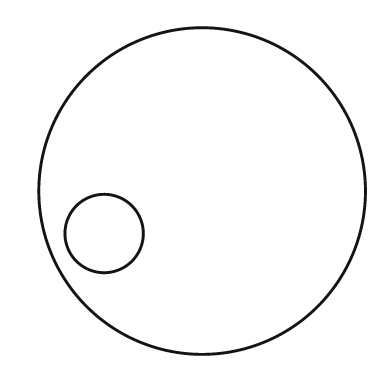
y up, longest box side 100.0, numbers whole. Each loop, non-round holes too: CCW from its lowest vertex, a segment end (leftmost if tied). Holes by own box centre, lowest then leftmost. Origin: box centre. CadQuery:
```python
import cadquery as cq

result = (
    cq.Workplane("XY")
    .moveTo(0.0, 0.0)
    .circle(50.0)
    .moveTo(-30.0, -13.0)
    .circle(12.0)
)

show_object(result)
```